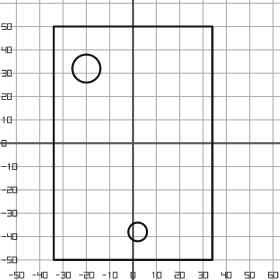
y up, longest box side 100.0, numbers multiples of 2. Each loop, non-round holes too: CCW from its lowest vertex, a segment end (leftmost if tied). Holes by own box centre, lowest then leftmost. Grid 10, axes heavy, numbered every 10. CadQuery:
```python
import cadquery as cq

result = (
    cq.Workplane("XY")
    .moveTo(-34.0, -50.0)
    .lineTo(34.0, -50.0)
    .lineTo(34.0, 50.0)
    .lineTo(-34.0, 50.0)
    .close()
    .moveTo(2.0, -38.0)
    .circle(4.0)
    .moveTo(-20.0, 32.0)
    .circle(6.0)
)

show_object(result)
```